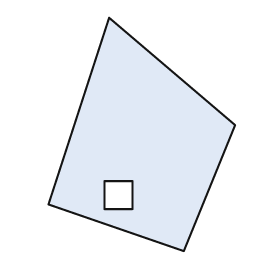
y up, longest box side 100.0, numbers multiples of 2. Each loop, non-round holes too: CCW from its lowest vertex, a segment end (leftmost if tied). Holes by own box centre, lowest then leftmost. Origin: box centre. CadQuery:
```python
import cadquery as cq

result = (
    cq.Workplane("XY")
    .moveTo(18.0, -50.0)
    .lineTo(40.0, 4.0)
    .lineTo(-14.0, 50.0)
    .lineTo(-40.0, -30.0)
    .close()
    .moveTo(-16.0, -32.0)
    .lineTo(-4.0, -32.0)
    .lineTo(-4.0, -20.0)
    .lineTo(-16.0, -20.0)
    .close()
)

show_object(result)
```